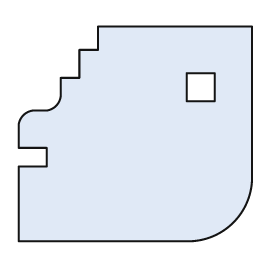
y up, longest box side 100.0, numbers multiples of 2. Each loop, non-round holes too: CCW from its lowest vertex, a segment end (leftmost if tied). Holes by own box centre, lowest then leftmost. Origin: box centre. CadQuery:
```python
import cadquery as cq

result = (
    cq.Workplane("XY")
    .moveTo(-50.0, -46.0)
    .lineTo(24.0, -46.0)
    .threePointArc((42.0, -38.0), (50.0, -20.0))
    .lineTo(50.0, 46.0)
    .lineTo(-16.0, 46.0)
    .lineTo(-16.0, 36.0)
    .lineTo(-24.0, 36.0)
    .lineTo(-24.0, 24.0)
    .lineTo(-32.0, 24.0)
    .lineTo(-32.0, 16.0)
    .threePointArc((-34.0, 12.0), (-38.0, 10.0))
    .lineTo(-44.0, 10.0)
    .threePointArc((-48.0, 8.0), (-50.0, 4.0))
    .lineTo(-50.0, -6.0)
    .lineTo(-38.0, -6.0)
    .lineTo(-38.0, -14.0)
    .lineTo(-50.0, -14.0)
    .close()
    .moveTo(22.0, 14.0)
    .lineTo(34.0, 14.0)
    .lineTo(34.0, 26.0)
    .lineTo(22.0, 26.0)
    .close()
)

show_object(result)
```